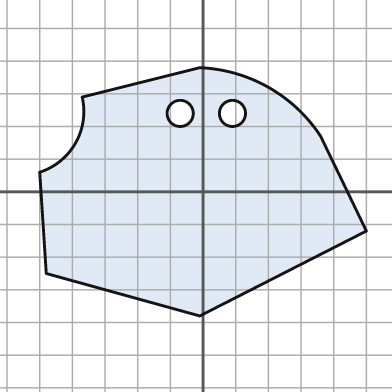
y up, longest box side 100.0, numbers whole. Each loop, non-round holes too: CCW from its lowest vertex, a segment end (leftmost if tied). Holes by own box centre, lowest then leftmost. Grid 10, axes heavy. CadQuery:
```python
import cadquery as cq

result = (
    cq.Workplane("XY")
    .moveTo(-1.0, -38.0)
    .lineTo(50.0, -12.0)
    .lineTo(36.0, 17.0)
    .threePointArc((20.0, 32.0), (-1.0, 38.0))
    .lineTo(-37.0, 29.0)
    .threePointArc((-39.0, 15.0), (-50.0, 6.0))
    .lineTo(-48.0, -25.0)
    .close()
    .moveTo(-7.0, 24.0)
    .circle(4.0)
    .moveTo(9.0, 24.0)
    .circle(4.0)
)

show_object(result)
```